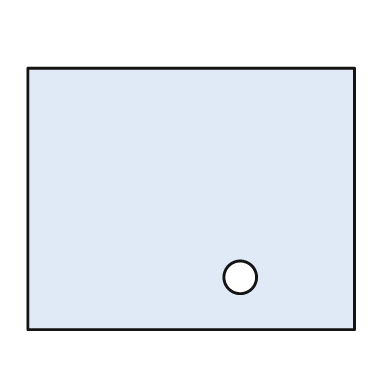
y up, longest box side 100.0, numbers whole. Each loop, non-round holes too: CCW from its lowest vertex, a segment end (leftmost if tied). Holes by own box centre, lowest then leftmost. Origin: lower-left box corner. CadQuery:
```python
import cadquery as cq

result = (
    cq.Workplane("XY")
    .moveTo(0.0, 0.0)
    .lineTo(100.0, 0.0)
    .lineTo(100.0, 80.0)
    .lineTo(0.0, 80.0)
    .close()
    .moveTo(65.0, 16.0)
    .circle(5.0)
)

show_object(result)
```